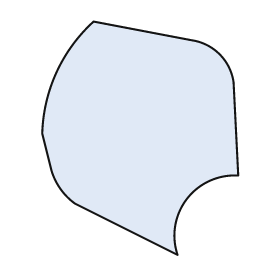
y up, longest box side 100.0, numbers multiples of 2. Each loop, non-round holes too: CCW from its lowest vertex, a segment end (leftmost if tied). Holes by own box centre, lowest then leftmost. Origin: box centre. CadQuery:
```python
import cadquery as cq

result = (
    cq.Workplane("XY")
    .moveTo(16.0, -50.0)
    .threePointArc((20.0, -26.0), (42.0, -16.0))
    .lineTo(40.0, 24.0)
    .threePointArc((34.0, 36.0), (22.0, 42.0))
    .lineTo(-20.0, 50.0)
    .threePointArc((-36.0, 28.0), (-42.0, 2.0))
    .lineTo(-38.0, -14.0)
    .threePointArc((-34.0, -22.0), (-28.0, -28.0))
    .close()
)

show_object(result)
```